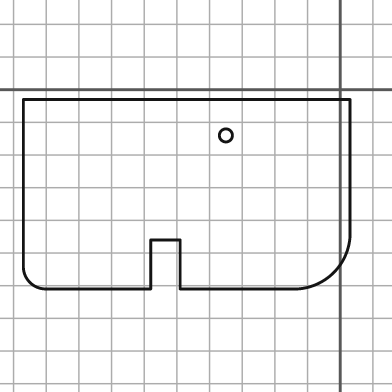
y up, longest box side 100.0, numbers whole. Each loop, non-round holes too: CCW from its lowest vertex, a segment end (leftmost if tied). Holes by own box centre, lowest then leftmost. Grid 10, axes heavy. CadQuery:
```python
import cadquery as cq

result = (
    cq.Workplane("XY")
    .moveTo(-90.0, -61.0)
    .lineTo(-58.0, -61.0)
    .lineTo(-58.0, -46.0)
    .lineTo(-49.0, -46.0)
    .lineTo(-49.0, -61.0)
    .lineTo(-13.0, -61.0)
    .threePointArc((-2.0, -56.0), (3.0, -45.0))
    .lineTo(3.0, -3.0)
    .lineTo(-97.0, -3.0)
    .lineTo(-97.0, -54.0)
    .threePointArc((-95.0, -59.0), (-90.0, -61.0))
    .close()
    .moveTo(-35.0, -14.0)
    .circle(2.0)
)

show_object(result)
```